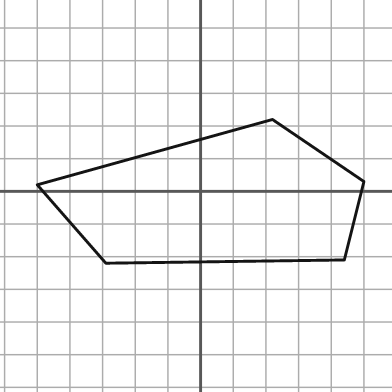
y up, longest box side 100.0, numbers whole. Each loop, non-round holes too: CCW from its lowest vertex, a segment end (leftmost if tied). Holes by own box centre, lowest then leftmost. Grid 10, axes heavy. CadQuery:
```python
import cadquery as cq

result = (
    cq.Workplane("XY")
    .moveTo(-29.0, -22.0)
    .lineTo(44.0, -21.0)
    .lineTo(50.0, 3.0)
    .lineTo(22.0, 22.0)
    .lineTo(-50.0, 2.0)
    .close()
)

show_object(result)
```